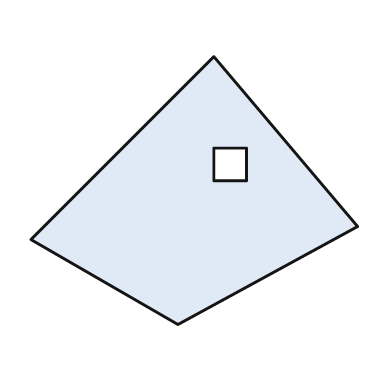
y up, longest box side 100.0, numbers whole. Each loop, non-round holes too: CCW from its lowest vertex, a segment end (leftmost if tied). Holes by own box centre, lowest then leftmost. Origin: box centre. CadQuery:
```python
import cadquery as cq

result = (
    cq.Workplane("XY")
    .moveTo(-5.0, -41.0)
    .lineTo(50.0, -11.0)
    .lineTo(6.0, 41.0)
    .lineTo(-50.0, -15.0)
    .close()
    .moveTo(6.0, 3.0)
    .lineTo(16.0, 3.0)
    .lineTo(16.0, 13.0)
    .lineTo(6.0, 13.0)
    .close()
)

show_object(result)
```